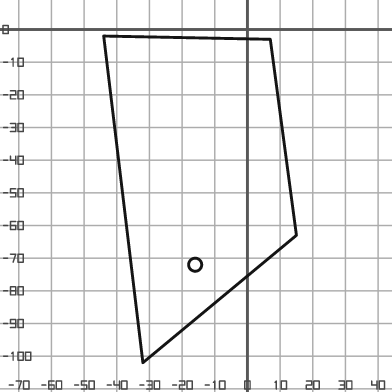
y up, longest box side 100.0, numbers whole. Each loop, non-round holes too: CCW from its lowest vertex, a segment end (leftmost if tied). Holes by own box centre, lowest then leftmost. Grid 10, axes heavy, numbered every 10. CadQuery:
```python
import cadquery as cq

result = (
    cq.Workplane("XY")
    .moveTo(-32.0, -102.0)
    .lineTo(15.0, -63.0)
    .lineTo(7.0, -3.0)
    .lineTo(-44.0, -2.0)
    .close()
    .moveTo(-16.0, -72.0)
    .circle(2.0)
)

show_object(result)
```